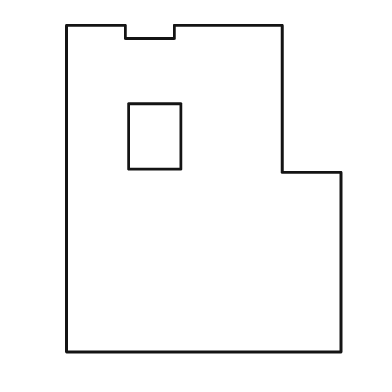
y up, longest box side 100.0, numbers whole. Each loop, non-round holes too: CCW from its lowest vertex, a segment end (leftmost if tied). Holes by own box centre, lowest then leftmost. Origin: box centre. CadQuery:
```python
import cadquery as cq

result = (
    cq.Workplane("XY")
    .moveTo(-42.0, -50.0)
    .lineTo(42.0, -50.0)
    .lineTo(42.0, 5.0)
    .lineTo(24.0, 5.0)
    .lineTo(24.0, 50.0)
    .lineTo(-9.0, 50.0)
    .lineTo(-9.0, 46.0)
    .lineTo(-24.0, 46.0)
    .lineTo(-24.0, 50.0)
    .lineTo(-42.0, 50.0)
    .close()
    .moveTo(-23.0, 6.0)
    .lineTo(-7.0, 6.0)
    .lineTo(-7.0, 26.0)
    .lineTo(-23.0, 26.0)
    .close()
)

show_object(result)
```